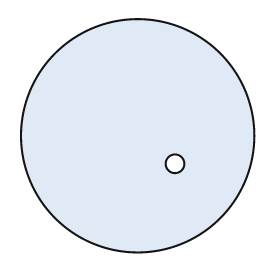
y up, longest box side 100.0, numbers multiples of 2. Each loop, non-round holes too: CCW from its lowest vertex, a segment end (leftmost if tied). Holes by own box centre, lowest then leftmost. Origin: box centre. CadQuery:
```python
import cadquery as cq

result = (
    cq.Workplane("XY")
    .moveTo(0.0, 0.0)
    .circle(50.0)
    .moveTo(16.0, -12.0)
    .circle(4.0)
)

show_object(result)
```